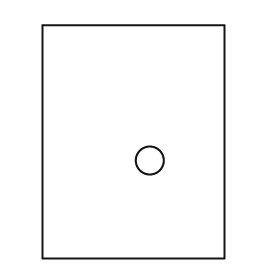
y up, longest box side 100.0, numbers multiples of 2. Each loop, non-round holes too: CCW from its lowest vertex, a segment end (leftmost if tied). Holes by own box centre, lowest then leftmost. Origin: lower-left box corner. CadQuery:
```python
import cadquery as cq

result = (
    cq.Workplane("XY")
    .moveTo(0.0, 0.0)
    .lineTo(78.0, 0.0)
    .lineTo(78.0, 100.0)
    .lineTo(0.0, 100.0)
    .close()
    .moveTo(46.0, 42.0)
    .circle(6.0)
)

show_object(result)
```